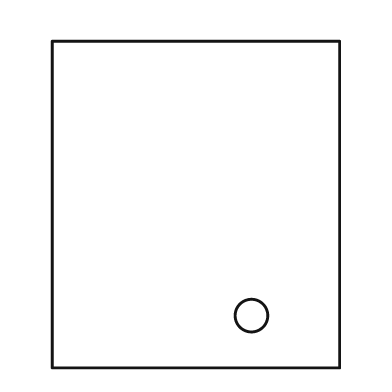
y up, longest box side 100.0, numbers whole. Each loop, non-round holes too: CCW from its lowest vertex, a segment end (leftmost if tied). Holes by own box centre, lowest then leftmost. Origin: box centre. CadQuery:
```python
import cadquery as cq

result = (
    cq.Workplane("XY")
    .moveTo(-44.0, -50.0)
    .lineTo(44.0, -50.0)
    .lineTo(44.0, 50.0)
    .lineTo(-44.0, 50.0)
    .close()
    .moveTo(17.0, -34.0)
    .circle(5.0)
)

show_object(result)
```